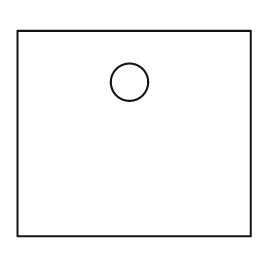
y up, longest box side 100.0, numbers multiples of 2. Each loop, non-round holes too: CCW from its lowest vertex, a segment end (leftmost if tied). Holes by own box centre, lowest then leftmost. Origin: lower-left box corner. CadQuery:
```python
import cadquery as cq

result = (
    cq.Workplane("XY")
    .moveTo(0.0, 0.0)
    .lineTo(100.0, 0.0)
    .lineTo(100.0, 88.0)
    .lineTo(0.0, 88.0)
    .close()
    .moveTo(48.0, 66.0)
    .circle(8.0)
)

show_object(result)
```